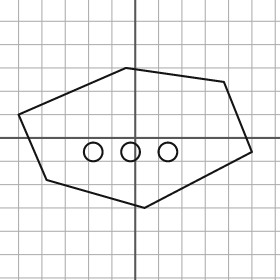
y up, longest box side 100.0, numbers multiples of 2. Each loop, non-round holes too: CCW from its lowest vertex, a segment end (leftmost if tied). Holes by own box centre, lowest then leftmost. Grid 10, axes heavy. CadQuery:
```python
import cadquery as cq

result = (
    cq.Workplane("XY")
    .moveTo(4.0, -30.0)
    .lineTo(50.0, -6.0)
    .lineTo(38.0, 24.0)
    .lineTo(-4.0, 30.0)
    .lineTo(-50.0, 10.0)
    .lineTo(-38.0, -18.0)
    .close()
    .moveTo(-18.0, -6.0)
    .circle(4.0)
    .moveTo(-2.0, -6.0)
    .circle(4.0)
    .moveTo(14.0, -6.0)
    .circle(4.0)
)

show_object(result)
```